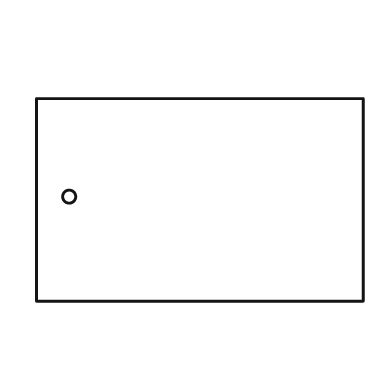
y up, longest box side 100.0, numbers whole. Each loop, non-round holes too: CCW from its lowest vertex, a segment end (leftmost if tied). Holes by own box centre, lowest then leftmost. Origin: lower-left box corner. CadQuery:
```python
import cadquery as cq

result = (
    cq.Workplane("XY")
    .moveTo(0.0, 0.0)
    .lineTo(100.0, 0.0)
    .lineTo(100.0, 62.0)
    .lineTo(0.0, 62.0)
    .close()
    .moveTo(10.0, 32.0)
    .circle(2.0)
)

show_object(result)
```